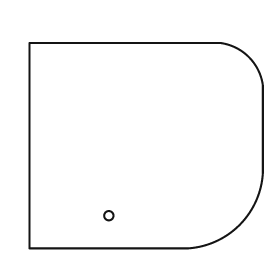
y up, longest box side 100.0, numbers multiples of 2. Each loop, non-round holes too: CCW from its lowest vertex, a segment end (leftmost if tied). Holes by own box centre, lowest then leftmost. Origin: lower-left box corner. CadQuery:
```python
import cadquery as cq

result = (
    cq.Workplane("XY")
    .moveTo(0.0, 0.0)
    .lineTo(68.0, 0.0)
    .threePointArc((90.0, 10.0), (100.0, 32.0))
    .lineTo(100.0, 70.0)
    .threePointArc((94.0, 82.0), (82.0, 88.0))
    .lineTo(0.0, 88.0)
    .close()
    .moveTo(34.0, 14.0)
    .circle(2.0)
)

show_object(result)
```